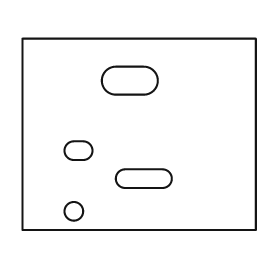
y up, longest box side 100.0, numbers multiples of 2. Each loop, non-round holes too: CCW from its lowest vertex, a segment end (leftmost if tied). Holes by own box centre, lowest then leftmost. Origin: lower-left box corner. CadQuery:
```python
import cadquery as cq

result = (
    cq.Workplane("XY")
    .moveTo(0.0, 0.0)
    .lineTo(100.0, 0.0)
    .lineTo(100.0, 82.0)
    .lineTo(0.0, 82.0)
    .close()
    .moveTo(22.0, 8.0)
    .circle(4.0)
    .moveTo(44.0, 18.0)
    .lineTo(60.0, 18.0)
    .threePointArc((64.0, 22.0), (60.0, 26.0))
    .lineTo(44.0, 26.0)
    .threePointArc((40.0, 22.0), (44.0, 18.0))
    .close()
    .moveTo(22.0, 30.0)
    .lineTo(26.0, 30.0)
    .threePointArc((30.0, 34.0), (26.0, 38.0))
    .lineTo(22.0, 38.0)
    .threePointArc((18.0, 34.0), (22.0, 30.0))
    .close()
    .moveTo(40.0, 58.0)
    .lineTo(52.0, 58.0)
    .threePointArc((58.0, 64.0), (52.0, 70.0))
    .lineTo(40.0, 70.0)
    .threePointArc((34.0, 64.0), (40.0, 58.0))
    .close()
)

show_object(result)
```